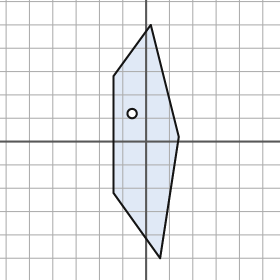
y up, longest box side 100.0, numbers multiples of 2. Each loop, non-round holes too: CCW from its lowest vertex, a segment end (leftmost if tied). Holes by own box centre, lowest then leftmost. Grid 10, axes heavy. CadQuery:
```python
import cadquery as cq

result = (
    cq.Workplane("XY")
    .moveTo(6.0, -50.0)
    .lineTo(14.0, 2.0)
    .lineTo(2.0, 50.0)
    .lineTo(-14.0, 28.0)
    .lineTo(-14.0, -22.0)
    .close()
    .moveTo(-6.0, 12.0)
    .circle(2.0)
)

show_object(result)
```